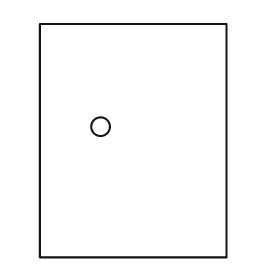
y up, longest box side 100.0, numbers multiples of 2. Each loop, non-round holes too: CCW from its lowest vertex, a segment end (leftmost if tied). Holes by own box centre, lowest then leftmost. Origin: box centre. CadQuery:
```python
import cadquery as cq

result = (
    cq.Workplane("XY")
    .moveTo(-40.0, -50.0)
    .lineTo(40.0, -50.0)
    .lineTo(40.0, 50.0)
    .lineTo(-40.0, 50.0)
    .close()
    .moveTo(-14.0, 6.0)
    .circle(4.0)
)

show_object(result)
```